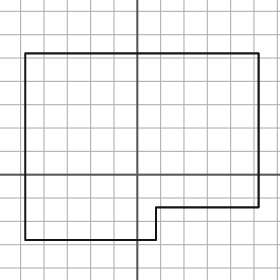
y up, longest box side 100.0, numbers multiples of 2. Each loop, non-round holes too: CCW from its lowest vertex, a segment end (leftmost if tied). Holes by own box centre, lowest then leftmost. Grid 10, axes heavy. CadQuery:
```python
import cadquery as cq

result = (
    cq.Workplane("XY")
    .moveTo(-48.0, -28.0)
    .lineTo(8.0, -28.0)
    .lineTo(8.0, -14.0)
    .lineTo(52.0, -14.0)
    .lineTo(52.0, 52.0)
    .lineTo(-48.0, 52.0)
    .close()
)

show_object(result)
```